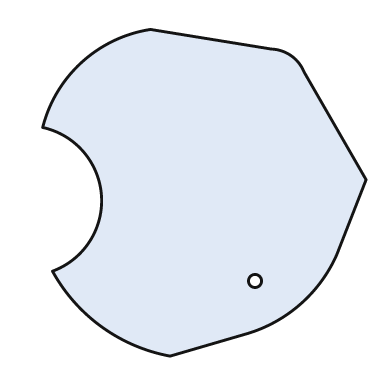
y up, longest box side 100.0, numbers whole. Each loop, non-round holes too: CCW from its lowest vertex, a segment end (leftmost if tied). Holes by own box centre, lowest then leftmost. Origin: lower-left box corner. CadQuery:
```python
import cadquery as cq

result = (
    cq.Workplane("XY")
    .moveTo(39.0, 0.0)
    .lineTo(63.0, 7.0)
    .threePointArc((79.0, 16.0), (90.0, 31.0))
    .lineTo(99.0, 54.0)
    .lineTo(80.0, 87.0)
    .threePointArc((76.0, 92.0), (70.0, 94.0))
    .lineTo(33.0, 100.0)
    .threePointArc((12.0, 90.0), (0.0, 70.0))
    .threePointArc((18.0, 49.0), (3.0, 26.0))
    .threePointArc((18.0, 9.0), (39.0, 0.0))
    .close()
    .moveTo(65.0, 23.0)
    .circle(2.0)
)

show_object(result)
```